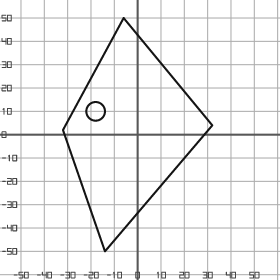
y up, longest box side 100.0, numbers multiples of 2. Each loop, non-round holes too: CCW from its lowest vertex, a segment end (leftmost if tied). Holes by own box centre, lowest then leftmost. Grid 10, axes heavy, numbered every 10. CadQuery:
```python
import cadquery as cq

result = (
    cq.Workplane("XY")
    .moveTo(-14.0, -50.0)
    .lineTo(32.0, 4.0)
    .lineTo(-6.0, 50.0)
    .lineTo(-32.0, 2.0)
    .close()
    .moveTo(-18.0, 10.0)
    .circle(4.0)
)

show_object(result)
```